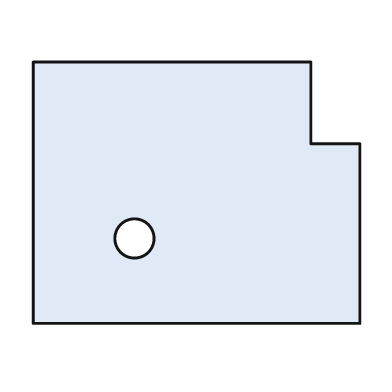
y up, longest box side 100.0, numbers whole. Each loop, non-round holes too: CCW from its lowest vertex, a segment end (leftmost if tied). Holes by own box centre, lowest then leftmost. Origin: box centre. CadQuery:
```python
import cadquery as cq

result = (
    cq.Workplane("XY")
    .moveTo(-50.0, -40.0)
    .lineTo(50.0, -40.0)
    .lineTo(50.0, 15.0)
    .lineTo(35.0, 15.0)
    .lineTo(35.0, 40.0)
    .lineTo(-50.0, 40.0)
    .close()
    .moveTo(-19.0, -14.0)
    .circle(6.0)
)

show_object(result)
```